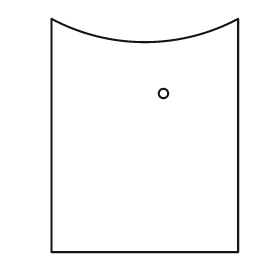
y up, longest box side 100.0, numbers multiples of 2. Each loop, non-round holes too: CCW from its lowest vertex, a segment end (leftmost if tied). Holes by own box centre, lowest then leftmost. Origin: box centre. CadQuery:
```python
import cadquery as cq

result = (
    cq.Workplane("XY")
    .moveTo(-40.0, -50.0)
    .lineTo(40.0, -50.0)
    .lineTo(40.0, 50.0)
    .threePointArc((0.0, 40.0), (-40.0, 50.0))
    .close()
    .moveTo(8.0, 18.0)
    .circle(2.0)
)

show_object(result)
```